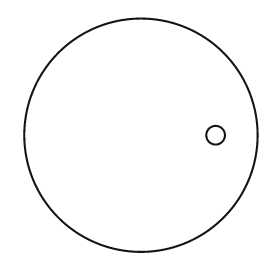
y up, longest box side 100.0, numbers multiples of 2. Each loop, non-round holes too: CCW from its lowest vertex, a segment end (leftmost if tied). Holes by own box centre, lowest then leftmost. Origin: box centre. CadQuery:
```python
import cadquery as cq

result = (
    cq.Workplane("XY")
    .moveTo(0.0, 0.0)
    .circle(50.0)
    .moveTo(32.0, 0.0)
    .circle(4.0)
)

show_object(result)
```